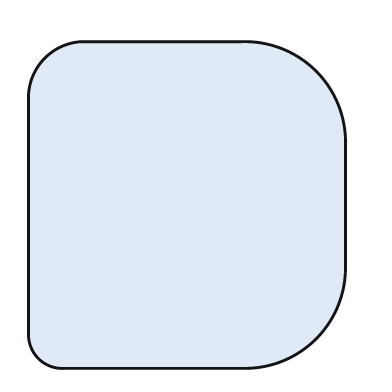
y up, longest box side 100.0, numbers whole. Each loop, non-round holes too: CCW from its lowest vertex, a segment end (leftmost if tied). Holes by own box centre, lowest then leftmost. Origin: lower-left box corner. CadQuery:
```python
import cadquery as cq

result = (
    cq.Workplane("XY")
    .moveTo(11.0, 0.0)
    .lineTo(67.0, 0.0)
    .threePointArc((88.0, 9.0), (97.0, 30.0))
    .lineTo(97.0, 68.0)
    .threePointArc((88.0, 91.0), (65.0, 100.0))
    .lineTo(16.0, 100.0)
    .threePointArc((5.0, 95.0), (0.0, 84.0))
    .lineTo(0.0, 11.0)
    .threePointArc((3.0, 3.0), (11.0, 0.0))
    .close()
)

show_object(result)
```